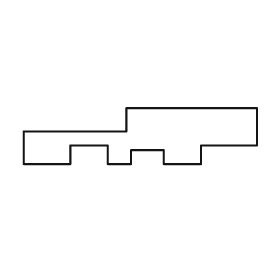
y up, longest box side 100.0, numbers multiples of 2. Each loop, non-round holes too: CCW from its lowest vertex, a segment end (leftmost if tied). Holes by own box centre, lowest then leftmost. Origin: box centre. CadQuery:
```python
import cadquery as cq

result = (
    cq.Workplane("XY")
    .moveTo(-50.0, -12.0)
    .lineTo(-30.0, -12.0)
    .lineTo(-30.0, -4.0)
    .lineTo(-14.0, -4.0)
    .lineTo(-14.0, -12.0)
    .lineTo(-4.0, -12.0)
    .lineTo(-4.0, -6.0)
    .lineTo(10.0, -6.0)
    .lineTo(10.0, -12.0)
    .lineTo(26.0, -12.0)
    .lineTo(26.0, -4.0)
    .lineTo(50.0, -4.0)
    .lineTo(50.0, 12.0)
    .lineTo(-6.0, 12.0)
    .lineTo(-6.0, 2.0)
    .lineTo(-50.0, 2.0)
    .close()
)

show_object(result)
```